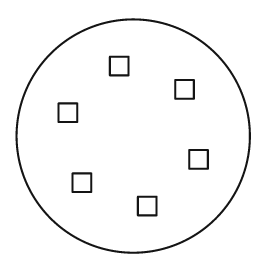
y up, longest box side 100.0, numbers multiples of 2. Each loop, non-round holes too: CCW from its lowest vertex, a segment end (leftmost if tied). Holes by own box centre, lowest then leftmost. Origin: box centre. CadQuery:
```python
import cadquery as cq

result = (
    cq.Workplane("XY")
    .moveTo(0.0, 0.0)
    .circle(50.0)
    .moveTo(2.0, -34.0)
    .lineTo(10.0, -34.0)
    .lineTo(10.0, -26.0)
    .lineTo(2.0, -26.0)
    .close()
    .moveTo(-26.0, -24.0)
    .lineTo(-18.0, -24.0)
    .lineTo(-18.0, -16.0)
    .lineTo(-26.0, -16.0)
    .close()
    .moveTo(24.0, -14.0)
    .lineTo(32.0, -14.0)
    .lineTo(32.0, -6.0)
    .lineTo(24.0, -6.0)
    .close()
    .moveTo(-32.0, 6.0)
    .lineTo(-24.0, 6.0)
    .lineTo(-24.0, 14.0)
    .lineTo(-32.0, 14.0)
    .close()
    .moveTo(18.0, 16.0)
    .lineTo(26.0, 16.0)
    .lineTo(26.0, 24.0)
    .lineTo(18.0, 24.0)
    .close()
    .moveTo(-10.0, 26.0)
    .lineTo(-2.0, 26.0)
    .lineTo(-2.0, 34.0)
    .lineTo(-10.0, 34.0)
    .close()
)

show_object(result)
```